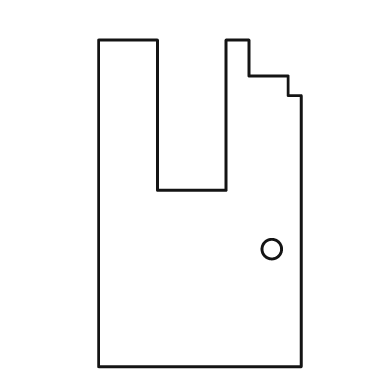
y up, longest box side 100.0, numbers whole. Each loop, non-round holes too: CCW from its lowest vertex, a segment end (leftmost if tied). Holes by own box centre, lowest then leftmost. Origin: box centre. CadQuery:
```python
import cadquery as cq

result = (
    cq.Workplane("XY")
    .moveTo(-31.0, -50.0)
    .lineTo(31.0, -50.0)
    .lineTo(31.0, 33.0)
    .lineTo(27.0, 33.0)
    .lineTo(27.0, 39.0)
    .lineTo(15.0, 39.0)
    .lineTo(15.0, 50.0)
    .lineTo(8.0, 50.0)
    .lineTo(8.0, 4.0)
    .lineTo(-13.0, 4.0)
    .lineTo(-13.0, 50.0)
    .lineTo(-31.0, 50.0)
    .close()
    .moveTo(22.0, -14.0)
    .circle(3.0)
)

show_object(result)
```